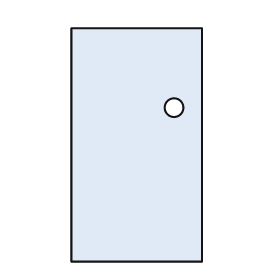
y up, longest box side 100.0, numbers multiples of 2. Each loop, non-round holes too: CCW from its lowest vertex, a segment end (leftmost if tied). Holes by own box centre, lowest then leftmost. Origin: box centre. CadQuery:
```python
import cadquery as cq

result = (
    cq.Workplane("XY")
    .moveTo(-28.0, -50.0)
    .lineTo(28.0, -50.0)
    .lineTo(28.0, 50.0)
    .lineTo(-28.0, 50.0)
    .close()
    .moveTo(16.0, 16.0)
    .circle(4.0)
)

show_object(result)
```